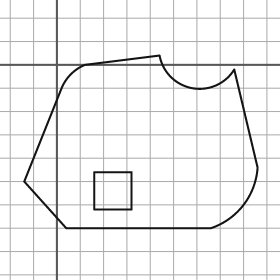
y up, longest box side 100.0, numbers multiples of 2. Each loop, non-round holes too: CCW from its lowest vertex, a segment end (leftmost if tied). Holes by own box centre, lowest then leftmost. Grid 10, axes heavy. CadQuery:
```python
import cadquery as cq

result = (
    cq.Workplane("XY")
    .moveTo(4.0, -70.0)
    .lineTo(66.0, -70.0)
    .threePointArc((80.0, -60.0), (86.0, -44.0))
    .lineTo(76.0, -2.0)
    .threePointArc((58.0, -10.0), (44.0, 4.0))
    .lineTo(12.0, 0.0)
    .threePointArc((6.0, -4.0), (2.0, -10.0))
    .lineTo(-14.0, -50.0)
    .close()
    .moveTo(16.0, -62.0)
    .lineTo(32.0, -62.0)
    .lineTo(32.0, -46.0)
    .lineTo(16.0, -46.0)
    .close()
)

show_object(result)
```